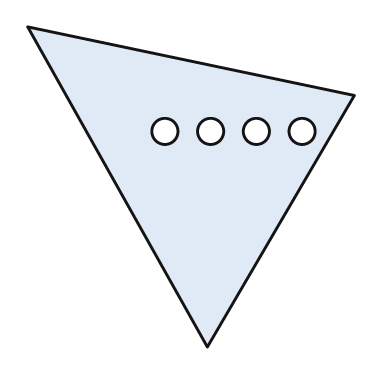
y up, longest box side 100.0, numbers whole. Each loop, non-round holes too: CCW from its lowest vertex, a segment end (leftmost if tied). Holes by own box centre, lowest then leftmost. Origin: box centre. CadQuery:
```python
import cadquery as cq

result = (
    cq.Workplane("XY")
    .moveTo(5.0, -49.0)
    .lineTo(50.0, 28.0)
    .lineTo(-50.0, 49.0)
    .close()
    .moveTo(-8.0, 17.0)
    .circle(4.0)
    .moveTo(6.0, 17.0)
    .circle(4.0)
    .moveTo(20.0, 17.0)
    .circle(4.0)
    .moveTo(34.0, 17.0)
    .circle(4.0)
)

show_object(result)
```